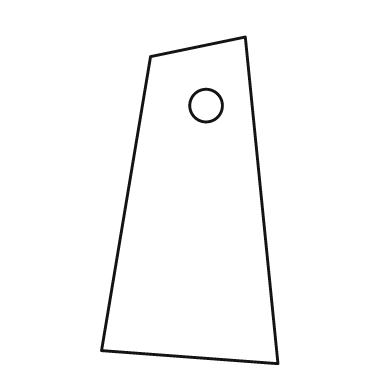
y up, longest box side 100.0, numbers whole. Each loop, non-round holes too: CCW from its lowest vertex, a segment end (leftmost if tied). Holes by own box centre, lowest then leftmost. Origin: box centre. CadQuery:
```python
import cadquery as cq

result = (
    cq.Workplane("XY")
    .moveTo(27.0, -50.0)
    .lineTo(17.0, 50.0)
    .lineTo(-12.0, 44.0)
    .lineTo(-27.0, -46.0)
    .close()
    .moveTo(5.0, 29.0)
    .circle(5.0)
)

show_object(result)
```